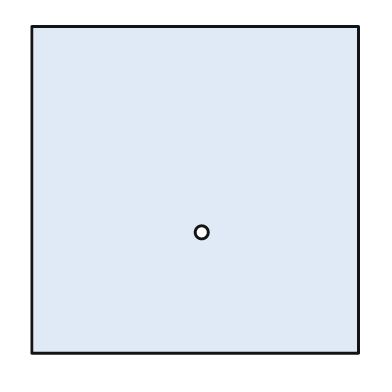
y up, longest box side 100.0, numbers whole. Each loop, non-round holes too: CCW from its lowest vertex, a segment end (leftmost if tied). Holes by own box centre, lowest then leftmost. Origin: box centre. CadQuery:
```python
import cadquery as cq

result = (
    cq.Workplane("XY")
    .moveTo(-50.0, -50.0)
    .lineTo(50.0, -50.0)
    .lineTo(50.0, 50.0)
    .lineTo(-50.0, 50.0)
    .close()
    .moveTo(2.0, -13.0)
    .circle(2.0)
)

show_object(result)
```